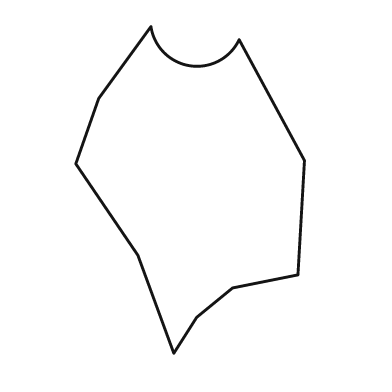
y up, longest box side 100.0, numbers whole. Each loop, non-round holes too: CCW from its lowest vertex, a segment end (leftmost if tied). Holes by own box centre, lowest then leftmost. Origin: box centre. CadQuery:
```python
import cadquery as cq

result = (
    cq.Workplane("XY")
    .moveTo(-5.0, -50.0)
    .lineTo(2.0, -39.0)
    .lineTo(13.0, -30.0)
    .lineTo(33.0, -26.0)
    .lineTo(35.0, 9.0)
    .lineTo(15.0, 46.0)
    .threePointArc((0.0, 38.0), (-12.0, 50.0))
    .lineTo(-28.0, 28.0)
    .lineTo(-35.0, 8.0)
    .lineTo(-16.0, -20.0)
    .close()
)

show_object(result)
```